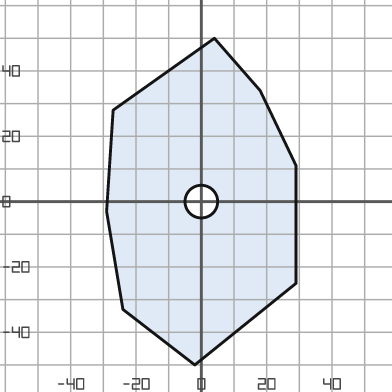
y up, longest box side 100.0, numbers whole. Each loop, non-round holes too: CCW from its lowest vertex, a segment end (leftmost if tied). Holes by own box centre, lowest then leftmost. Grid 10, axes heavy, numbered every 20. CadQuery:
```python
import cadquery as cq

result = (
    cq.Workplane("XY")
    .moveTo(-2.0, -50.0)
    .lineTo(29.0, -25.0)
    .lineTo(29.0, 11.0)
    .lineTo(18.0, 34.0)
    .lineTo(4.0, 50.0)
    .lineTo(-27.0, 28.0)
    .lineTo(-29.0, -3.0)
    .lineTo(-24.0, -33.0)
    .close()
    .moveTo(0.0, 0.0)
    .circle(5.0)
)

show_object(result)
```